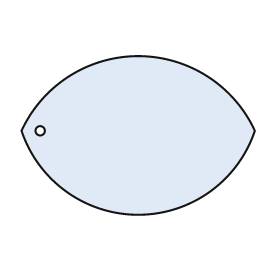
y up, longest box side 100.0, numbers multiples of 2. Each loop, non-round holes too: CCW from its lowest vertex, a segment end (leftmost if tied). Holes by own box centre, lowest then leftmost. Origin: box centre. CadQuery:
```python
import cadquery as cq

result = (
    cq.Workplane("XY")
    .moveTo(-50.0, 2.0)
    .threePointArc((0.0, -34.0), (50.0, 2.0))
    .threePointArc((0.0, 34.0), (-50.0, 2.0))
    .close()
    .moveTo(-42.0, 2.0)
    .circle(2.0)
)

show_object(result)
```